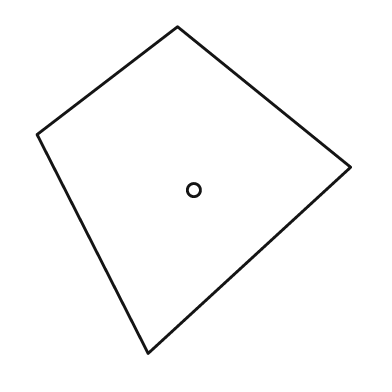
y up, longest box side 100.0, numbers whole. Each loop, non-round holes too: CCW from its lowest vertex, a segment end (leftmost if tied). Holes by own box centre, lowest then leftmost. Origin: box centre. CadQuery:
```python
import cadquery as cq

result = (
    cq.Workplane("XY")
    .moveTo(-14.0, -50.0)
    .lineTo(48.0, 7.0)
    .lineTo(-5.0, 50.0)
    .lineTo(-48.0, 17.0)
    .close()
    .moveTo(0.0, 0.0)
    .circle(2.0)
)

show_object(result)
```